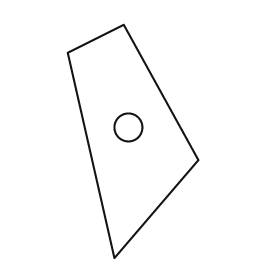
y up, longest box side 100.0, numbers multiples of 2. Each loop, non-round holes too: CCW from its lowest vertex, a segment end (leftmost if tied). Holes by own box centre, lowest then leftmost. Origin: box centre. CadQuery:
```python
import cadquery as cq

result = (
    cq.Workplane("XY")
    .moveTo(-8.0, -50.0)
    .lineTo(28.0, -8.0)
    .lineTo(-4.0, 50.0)
    .lineTo(-28.0, 38.0)
    .close()
    .moveTo(-2.0, 6.0)
    .circle(6.0)
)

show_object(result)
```